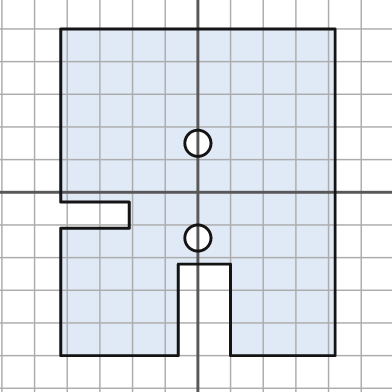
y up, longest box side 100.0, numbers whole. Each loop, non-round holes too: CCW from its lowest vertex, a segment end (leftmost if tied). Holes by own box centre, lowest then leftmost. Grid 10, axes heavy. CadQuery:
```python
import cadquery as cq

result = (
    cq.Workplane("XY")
    .moveTo(-42.0, -50.0)
    .lineTo(-6.0, -50.0)
    .lineTo(-6.0, -22.0)
    .lineTo(10.0, -22.0)
    .lineTo(10.0, -50.0)
    .lineTo(42.0, -50.0)
    .lineTo(42.0, 50.0)
    .lineTo(-42.0, 50.0)
    .lineTo(-42.0, -3.0)
    .lineTo(-21.0, -3.0)
    .lineTo(-21.0, -11.0)
    .lineTo(-42.0, -11.0)
    .close()
    .moveTo(0.0, -14.0)
    .circle(4.0)
    .moveTo(0.0, 15.0)
    .circle(4.0)
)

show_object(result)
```